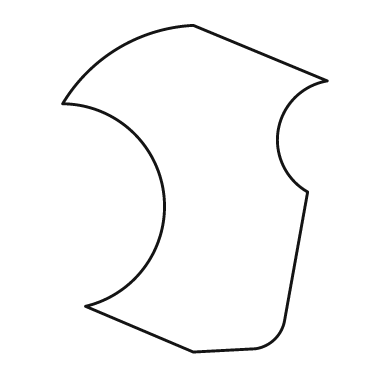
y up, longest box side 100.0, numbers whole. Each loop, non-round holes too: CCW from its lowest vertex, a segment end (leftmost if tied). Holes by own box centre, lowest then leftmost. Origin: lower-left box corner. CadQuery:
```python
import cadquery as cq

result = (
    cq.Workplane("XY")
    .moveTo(40.0, 0.0)
    .lineTo(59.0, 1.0)
    .threePointArc((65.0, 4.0), (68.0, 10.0))
    .lineTo(75.0, 49.0)
    .threePointArc((66.0, 68.0), (81.0, 83.0))
    .lineTo(40.0, 100.0)
    .threePointArc((17.0, 93.0), (0.0, 76.0))
    .threePointArc((31.0, 48.0), (7.0, 14.0))
    .close()
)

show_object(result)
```